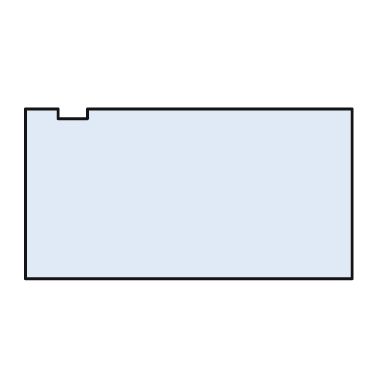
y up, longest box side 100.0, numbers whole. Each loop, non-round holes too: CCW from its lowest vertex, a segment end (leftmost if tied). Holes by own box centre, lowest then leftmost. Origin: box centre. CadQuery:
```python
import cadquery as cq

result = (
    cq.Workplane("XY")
    .moveTo(-50.0, -26.0)
    .lineTo(50.0, -26.0)
    .lineTo(50.0, 26.0)
    .lineTo(-31.0, 26.0)
    .lineTo(-31.0, 23.0)
    .lineTo(-40.0, 23.0)
    .lineTo(-40.0, 26.0)
    .lineTo(-50.0, 26.0)
    .close()
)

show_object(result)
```